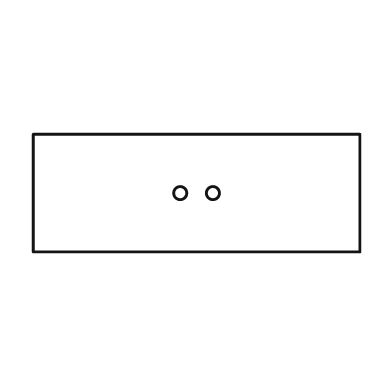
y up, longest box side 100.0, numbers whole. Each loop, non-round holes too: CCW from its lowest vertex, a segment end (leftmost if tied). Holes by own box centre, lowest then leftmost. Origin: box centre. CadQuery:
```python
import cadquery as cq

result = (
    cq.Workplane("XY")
    .moveTo(-50.0, -18.0)
    .lineTo(50.0, -18.0)
    .lineTo(50.0, 18.0)
    .lineTo(-50.0, 18.0)
    .close()
    .moveTo(-5.0, 0.0)
    .circle(2.0)
    .moveTo(5.0, 0.0)
    .circle(2.0)
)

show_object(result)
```